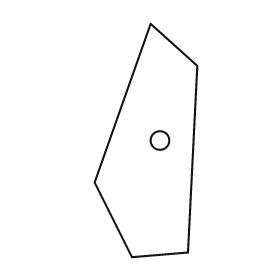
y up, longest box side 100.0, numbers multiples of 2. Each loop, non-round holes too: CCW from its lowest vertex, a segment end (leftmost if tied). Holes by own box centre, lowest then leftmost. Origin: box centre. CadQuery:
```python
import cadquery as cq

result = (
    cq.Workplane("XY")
    .moveTo(-6.0, -50.0)
    .lineTo(18.0, -48.0)
    .lineTo(22.0, 32.0)
    .lineTo(2.0, 50.0)
    .lineTo(-22.0, -18.0)
    .close()
    .moveTo(6.0, 0.0)
    .circle(4.0)
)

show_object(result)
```